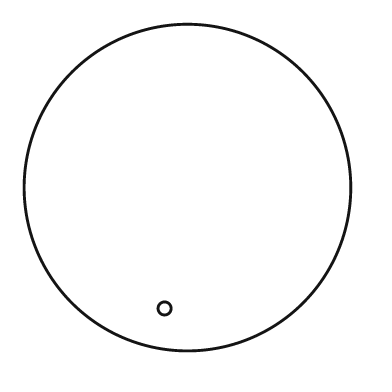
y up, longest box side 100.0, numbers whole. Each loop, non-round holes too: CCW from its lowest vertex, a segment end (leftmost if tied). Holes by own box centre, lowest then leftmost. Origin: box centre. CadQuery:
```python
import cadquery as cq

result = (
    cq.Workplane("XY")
    .moveTo(0.0, 0.0)
    .circle(50.0)
    .moveTo(-7.0, -37.0)
    .circle(2.0)
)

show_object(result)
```